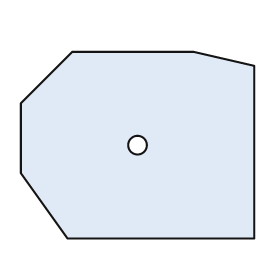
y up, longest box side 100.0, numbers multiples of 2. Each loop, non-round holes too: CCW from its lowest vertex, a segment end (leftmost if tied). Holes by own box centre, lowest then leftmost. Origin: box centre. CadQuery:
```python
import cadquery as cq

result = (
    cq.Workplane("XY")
    .moveTo(-30.0, -40.0)
    .lineTo(50.0, -40.0)
    .lineTo(50.0, 34.0)
    .lineTo(24.0, 40.0)
    .lineTo(-28.0, 40.0)
    .lineTo(-50.0, 18.0)
    .lineTo(-50.0, -12.0)
    .close()
    .moveTo(0.0, 0.0)
    .circle(4.0)
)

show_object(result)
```